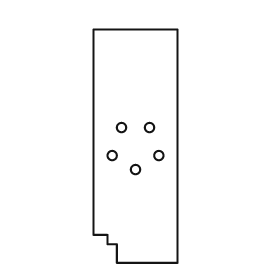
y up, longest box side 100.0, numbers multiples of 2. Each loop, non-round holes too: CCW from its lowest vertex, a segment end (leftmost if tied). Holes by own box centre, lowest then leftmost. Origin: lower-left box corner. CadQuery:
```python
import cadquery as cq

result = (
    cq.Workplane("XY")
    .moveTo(10.0, 0.0)
    .lineTo(36.0, 0.0)
    .lineTo(36.0, 100.0)
    .lineTo(0.0, 100.0)
    .lineTo(0.0, 12.0)
    .lineTo(6.0, 12.0)
    .lineTo(6.0, 8.0)
    .lineTo(10.0, 8.0)
    .close()
    .moveTo(18.0, 40.0)
    .circle(2.0)
    .moveTo(8.0, 46.0)
    .circle(2.0)
    .moveTo(28.0, 46.0)
    .circle(2.0)
    .moveTo(12.0, 58.0)
    .circle(2.0)
    .moveTo(24.0, 58.0)
    .circle(2.0)
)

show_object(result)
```